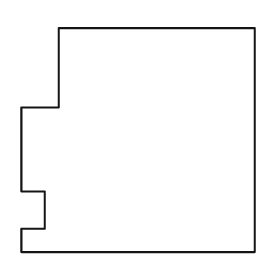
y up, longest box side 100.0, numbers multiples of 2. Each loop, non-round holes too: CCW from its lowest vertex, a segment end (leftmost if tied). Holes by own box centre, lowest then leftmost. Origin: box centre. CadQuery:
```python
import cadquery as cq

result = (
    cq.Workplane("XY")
    .moveTo(-50.0, -48.0)
    .lineTo(50.0, -48.0)
    .lineTo(50.0, 48.0)
    .lineTo(-34.0, 48.0)
    .lineTo(-34.0, 14.0)
    .lineTo(-50.0, 14.0)
    .lineTo(-50.0, -22.0)
    .lineTo(-40.0, -22.0)
    .lineTo(-40.0, -38.0)
    .lineTo(-50.0, -38.0)
    .close()
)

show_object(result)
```